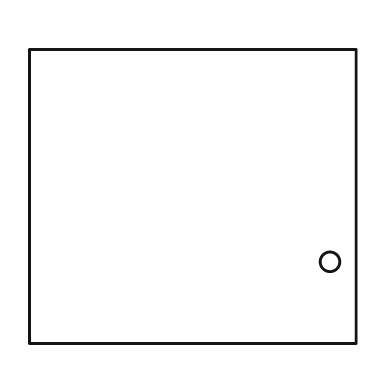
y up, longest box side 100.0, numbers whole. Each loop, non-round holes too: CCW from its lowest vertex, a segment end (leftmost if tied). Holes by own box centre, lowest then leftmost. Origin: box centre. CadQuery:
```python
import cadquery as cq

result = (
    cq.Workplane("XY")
    .moveTo(-50.0, -45.0)
    .lineTo(50.0, -45.0)
    .lineTo(50.0, 45.0)
    .lineTo(-50.0, 45.0)
    .close()
    .moveTo(42.0, -20.0)
    .circle(3.0)
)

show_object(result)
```